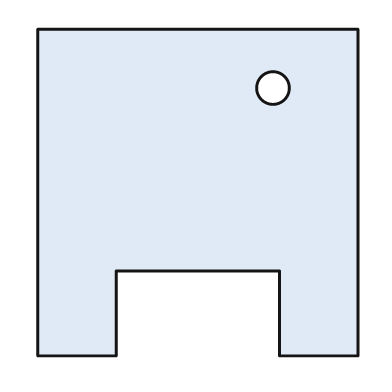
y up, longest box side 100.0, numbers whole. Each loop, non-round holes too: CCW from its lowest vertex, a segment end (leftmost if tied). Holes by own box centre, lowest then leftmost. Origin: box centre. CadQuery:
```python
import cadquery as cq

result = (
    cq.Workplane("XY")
    .moveTo(-49.0, -50.0)
    .lineTo(-25.0, -50.0)
    .lineTo(-25.0, -24.0)
    .lineTo(25.0, -24.0)
    .lineTo(25.0, -50.0)
    .lineTo(49.0, -50.0)
    .lineTo(49.0, 50.0)
    .lineTo(-49.0, 50.0)
    .close()
    .moveTo(23.0, 32.0)
    .circle(5.0)
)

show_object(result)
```